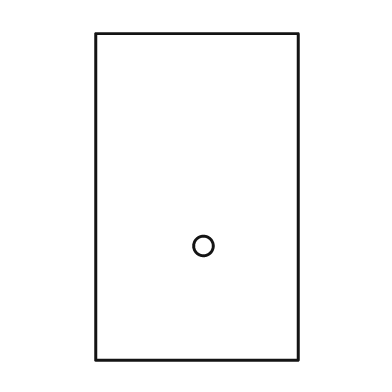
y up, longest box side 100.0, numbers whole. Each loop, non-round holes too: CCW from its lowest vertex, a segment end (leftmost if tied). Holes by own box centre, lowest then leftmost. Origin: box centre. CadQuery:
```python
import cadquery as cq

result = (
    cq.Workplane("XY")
    .moveTo(-31.0, -50.0)
    .lineTo(31.0, -50.0)
    .lineTo(31.0, 50.0)
    .lineTo(-31.0, 50.0)
    .close()
    .moveTo(2.0, -15.0)
    .circle(3.0)
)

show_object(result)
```